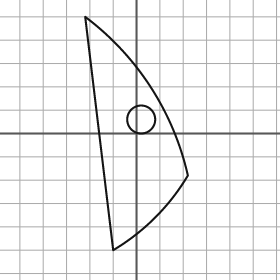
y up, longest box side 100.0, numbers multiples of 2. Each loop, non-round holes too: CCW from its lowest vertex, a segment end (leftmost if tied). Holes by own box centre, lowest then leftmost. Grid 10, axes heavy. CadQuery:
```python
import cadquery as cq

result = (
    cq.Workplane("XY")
    .moveTo(-10.0, -50.0)
    .threePointArc((8.0, -36.0), (22.0, -18.0))
    .threePointArc((6.0, 20.0), (-22.0, 50.0))
    .close()
    .moveTo(2.0, 6.0)
    .circle(6.0)
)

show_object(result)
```